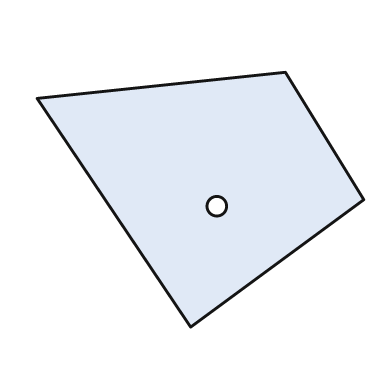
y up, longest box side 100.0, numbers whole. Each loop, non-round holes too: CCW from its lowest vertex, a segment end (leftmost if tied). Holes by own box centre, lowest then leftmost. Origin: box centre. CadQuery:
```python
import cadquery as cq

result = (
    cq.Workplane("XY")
    .moveTo(-3.0, -39.0)
    .lineTo(50.0, 0.0)
    .lineTo(26.0, 39.0)
    .lineTo(-50.0, 31.0)
    .close()
    .moveTo(5.0, -2.0)
    .circle(3.0)
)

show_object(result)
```